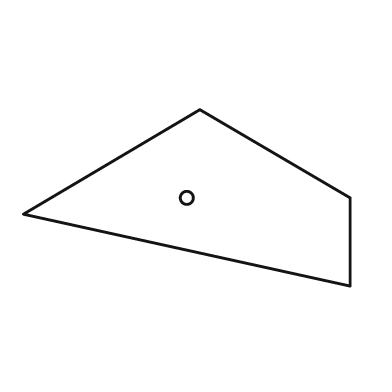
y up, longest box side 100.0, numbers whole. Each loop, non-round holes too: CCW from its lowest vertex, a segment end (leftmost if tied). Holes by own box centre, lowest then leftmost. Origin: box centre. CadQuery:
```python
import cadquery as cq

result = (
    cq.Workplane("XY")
    .moveTo(50.0, -27.0)
    .lineTo(50.0, 0.0)
    .lineTo(4.0, 27.0)
    .lineTo(-50.0, -5.0)
    .close()
    .moveTo(0.0, 0.0)
    .circle(2.0)
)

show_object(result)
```